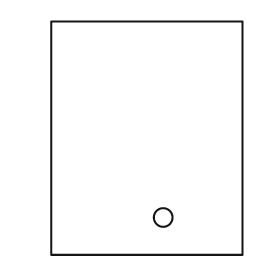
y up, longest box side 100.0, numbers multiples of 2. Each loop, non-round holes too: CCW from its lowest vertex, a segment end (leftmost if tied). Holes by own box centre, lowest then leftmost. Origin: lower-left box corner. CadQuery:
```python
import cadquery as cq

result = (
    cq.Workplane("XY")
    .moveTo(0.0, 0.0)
    .lineTo(82.0, 0.0)
    .lineTo(82.0, 100.0)
    .lineTo(0.0, 100.0)
    .close()
    .moveTo(48.0, 16.0)
    .circle(4.0)
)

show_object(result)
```